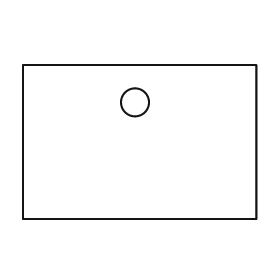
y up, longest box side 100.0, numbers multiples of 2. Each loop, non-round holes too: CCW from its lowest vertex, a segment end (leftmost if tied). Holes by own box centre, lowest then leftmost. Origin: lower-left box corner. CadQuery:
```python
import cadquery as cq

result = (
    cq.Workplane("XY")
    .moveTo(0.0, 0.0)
    .lineTo(100.0, 0.0)
    .lineTo(100.0, 66.0)
    .lineTo(0.0, 66.0)
    .close()
    .moveTo(48.0, 50.0)
    .circle(6.0)
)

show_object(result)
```